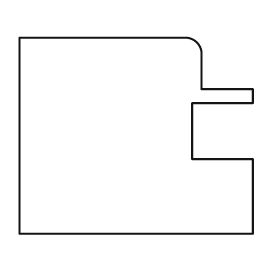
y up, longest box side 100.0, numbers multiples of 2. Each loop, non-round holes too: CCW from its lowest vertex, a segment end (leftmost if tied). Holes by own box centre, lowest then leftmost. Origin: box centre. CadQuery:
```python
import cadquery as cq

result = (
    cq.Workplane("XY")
    .moveTo(-50.0, -42.0)
    .lineTo(50.0, -42.0)
    .lineTo(50.0, -10.0)
    .lineTo(24.0, -10.0)
    .lineTo(24.0, 14.0)
    .lineTo(50.0, 14.0)
    .lineTo(50.0, 20.0)
    .lineTo(28.0, 20.0)
    .lineTo(28.0, 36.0)
    .threePointArc((26.0, 40.0), (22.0, 42.0))
    .lineTo(-50.0, 42.0)
    .close()
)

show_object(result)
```